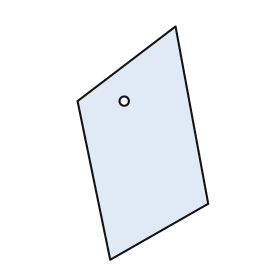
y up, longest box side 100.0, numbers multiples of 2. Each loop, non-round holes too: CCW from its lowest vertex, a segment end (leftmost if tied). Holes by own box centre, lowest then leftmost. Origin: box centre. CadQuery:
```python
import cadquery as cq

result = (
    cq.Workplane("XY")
    .moveTo(-14.0, -50.0)
    .lineTo(28.0, -26.0)
    .lineTo(14.0, 50.0)
    .lineTo(-28.0, 18.0)
    .close()
    .moveTo(-8.0, 18.0)
    .circle(2.0)
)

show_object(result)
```